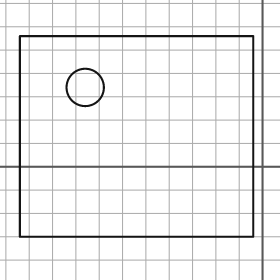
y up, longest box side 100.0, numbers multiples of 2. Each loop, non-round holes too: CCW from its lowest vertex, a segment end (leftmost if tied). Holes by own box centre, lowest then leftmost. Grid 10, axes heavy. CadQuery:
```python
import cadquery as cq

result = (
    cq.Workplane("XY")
    .moveTo(-104.0, -30.0)
    .lineTo(-4.0, -30.0)
    .lineTo(-4.0, 56.0)
    .lineTo(-104.0, 56.0)
    .close()
    .moveTo(-76.0, 34.0)
    .circle(8.0)
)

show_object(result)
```